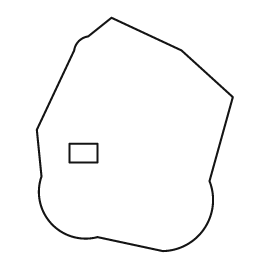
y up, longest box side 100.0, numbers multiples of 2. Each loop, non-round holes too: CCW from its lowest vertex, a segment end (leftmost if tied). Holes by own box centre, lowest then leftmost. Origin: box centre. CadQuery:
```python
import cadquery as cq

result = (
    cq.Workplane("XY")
    .moveTo(12.0, -50.0)
    .threePointArc((30.0, -40.0), (32.0, -20.0))
    .lineTo(42.0, 16.0)
    .lineTo(20.0, 36.0)
    .lineTo(-10.0, 50.0)
    .lineTo(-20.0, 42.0)
    .threePointArc((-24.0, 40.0), (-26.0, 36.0))
    .lineTo(-42.0, 2.0)
    .lineTo(-40.0, -18.0)
    .threePointArc((-36.0, -38.0), (-16.0, -44.0))
    .close()
    .moveTo(-28.0, -12.0)
    .lineTo(-16.0, -12.0)
    .lineTo(-16.0, -4.0)
    .lineTo(-28.0, -4.0)
    .close()
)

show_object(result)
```